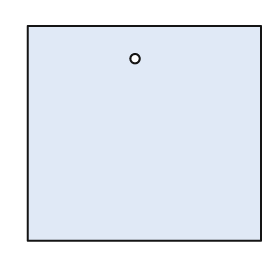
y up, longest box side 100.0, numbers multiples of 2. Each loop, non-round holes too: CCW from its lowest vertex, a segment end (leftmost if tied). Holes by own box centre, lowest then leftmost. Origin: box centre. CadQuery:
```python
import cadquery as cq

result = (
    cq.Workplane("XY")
    .moveTo(-50.0, -46.0)
    .lineTo(50.0, -46.0)
    .lineTo(50.0, 46.0)
    .lineTo(-50.0, 46.0)
    .close()
    .moveTo(-4.0, 32.0)
    .circle(2.0)
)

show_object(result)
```